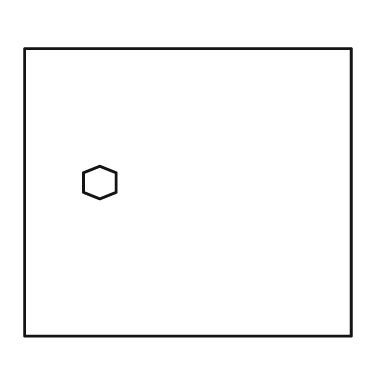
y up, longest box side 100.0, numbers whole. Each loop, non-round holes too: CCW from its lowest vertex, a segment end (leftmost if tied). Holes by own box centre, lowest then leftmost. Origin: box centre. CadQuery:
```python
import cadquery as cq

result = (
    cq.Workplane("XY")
    .moveTo(-50.0, -44.0)
    .lineTo(50.0, -44.0)
    .lineTo(50.0, 44.0)
    .lineTo(-50.0, 44.0)
    .close()
    .moveTo(-27.0, -2.0)
    .lineTo(-22.0, 0.0)
    .lineTo(-22.0, 6.0)
    .lineTo(-27.0, 8.0)
    .lineTo(-32.0, 6.0)
    .lineTo(-32.0, 0.0)
    .close()
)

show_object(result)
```